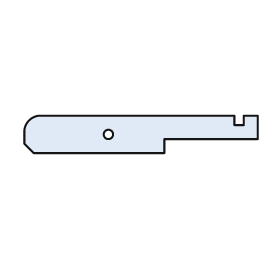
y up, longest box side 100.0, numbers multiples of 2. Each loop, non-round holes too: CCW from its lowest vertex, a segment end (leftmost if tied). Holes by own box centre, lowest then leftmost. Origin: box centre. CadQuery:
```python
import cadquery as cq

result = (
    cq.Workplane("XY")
    .moveTo(-46.0, -8.0)
    .lineTo(10.0, -8.0)
    .lineTo(10.0, -2.0)
    .lineTo(50.0, -2.0)
    .lineTo(50.0, 8.0)
    .lineTo(44.0, 8.0)
    .lineTo(44.0, 4.0)
    .lineTo(40.0, 4.0)
    .lineTo(40.0, 8.0)
    .lineTo(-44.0, 8.0)
    .threePointArc((-48.0, 6.0), (-50.0, 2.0))
    .lineTo(-50.0, -4.0)
    .close()
    .moveTo(-14.0, 0.0)
    .circle(2.0)
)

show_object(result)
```